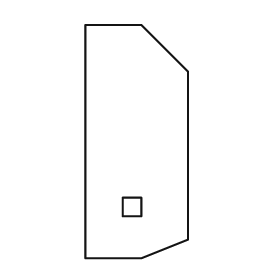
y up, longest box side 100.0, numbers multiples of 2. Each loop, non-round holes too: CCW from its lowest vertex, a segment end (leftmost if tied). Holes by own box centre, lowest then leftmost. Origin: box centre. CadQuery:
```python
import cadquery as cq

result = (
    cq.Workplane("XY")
    .moveTo(-22.0, -50.0)
    .lineTo(2.0, -50.0)
    .lineTo(22.0, -42.0)
    .lineTo(22.0, 30.0)
    .lineTo(2.0, 50.0)
    .lineTo(-22.0, 50.0)
    .close()
    .moveTo(-6.0, -32.0)
    .lineTo(2.0, -32.0)
    .lineTo(2.0, -24.0)
    .lineTo(-6.0, -24.0)
    .close()
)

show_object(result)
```